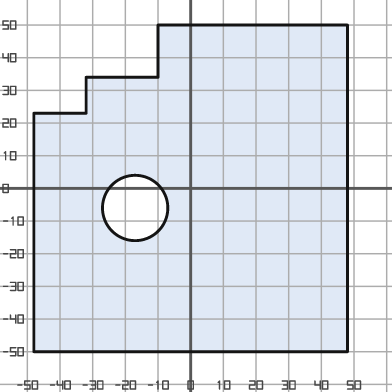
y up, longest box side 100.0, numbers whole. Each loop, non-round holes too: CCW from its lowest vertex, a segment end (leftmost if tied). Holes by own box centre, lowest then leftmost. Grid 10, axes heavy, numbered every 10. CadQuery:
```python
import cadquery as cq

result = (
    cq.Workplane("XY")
    .moveTo(-48.0, -50.0)
    .lineTo(48.0, -50.0)
    .lineTo(48.0, 50.0)
    .lineTo(-10.0, 50.0)
    .lineTo(-10.0, 34.0)
    .lineTo(-32.0, 34.0)
    .lineTo(-32.0, 23.0)
    .lineTo(-48.0, 23.0)
    .close()
    .moveTo(-17.0, -6.0)
    .circle(10.0)
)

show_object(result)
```